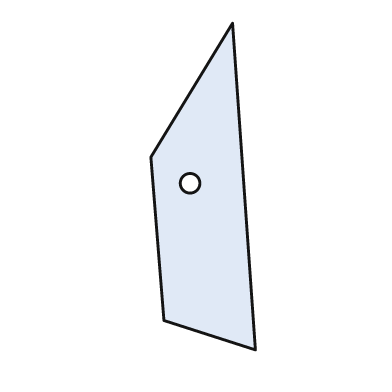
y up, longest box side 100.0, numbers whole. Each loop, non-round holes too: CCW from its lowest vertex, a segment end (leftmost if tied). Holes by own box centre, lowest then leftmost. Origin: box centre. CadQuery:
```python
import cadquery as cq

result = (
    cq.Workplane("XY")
    .moveTo(16.0, -50.0)
    .lineTo(9.0, 50.0)
    .lineTo(-16.0, 9.0)
    .lineTo(-12.0, -41.0)
    .close()
    .moveTo(-4.0, 1.0)
    .circle(3.0)
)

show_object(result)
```